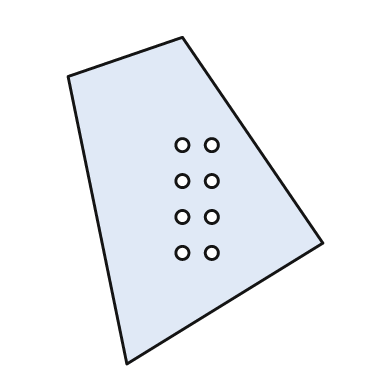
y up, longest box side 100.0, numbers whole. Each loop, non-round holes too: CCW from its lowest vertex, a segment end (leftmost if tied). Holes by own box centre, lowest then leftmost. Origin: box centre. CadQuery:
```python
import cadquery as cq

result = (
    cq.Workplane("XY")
    .moveTo(-21.0, -50.0)
    .lineTo(39.0, -13.0)
    .lineTo(-4.0, 50.0)
    .lineTo(-39.0, 38.0)
    .close()
    .moveTo(-4.0, -16.0)
    .circle(2.0)
    .moveTo(5.0, -16.0)
    .circle(2.0)
    .moveTo(-4.0, -5.0)
    .circle(2.0)
    .moveTo(5.0, -5.0)
    .circle(2.0)
    .moveTo(-4.0, 6.0)
    .circle(2.0)
    .moveTo(5.0, 6.0)
    .circle(2.0)
    .moveTo(-4.0, 17.0)
    .circle(2.0)
    .moveTo(5.0, 17.0)
    .circle(2.0)
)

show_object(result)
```